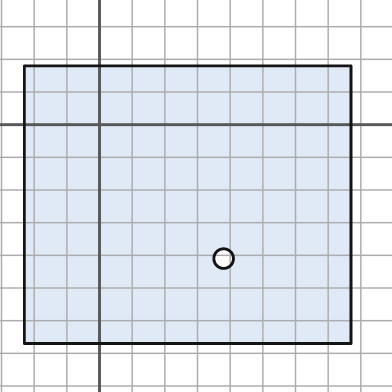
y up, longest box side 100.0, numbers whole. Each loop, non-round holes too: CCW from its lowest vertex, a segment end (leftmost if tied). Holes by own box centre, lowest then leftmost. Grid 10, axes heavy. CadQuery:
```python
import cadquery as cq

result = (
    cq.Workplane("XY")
    .moveTo(-23.0, -67.0)
    .lineTo(77.0, -67.0)
    .lineTo(77.0, 18.0)
    .lineTo(-23.0, 18.0)
    .close()
    .moveTo(38.0, -41.0)
    .circle(3.0)
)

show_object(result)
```